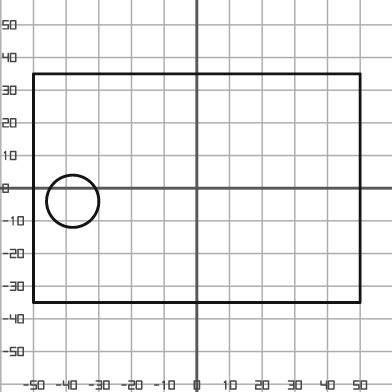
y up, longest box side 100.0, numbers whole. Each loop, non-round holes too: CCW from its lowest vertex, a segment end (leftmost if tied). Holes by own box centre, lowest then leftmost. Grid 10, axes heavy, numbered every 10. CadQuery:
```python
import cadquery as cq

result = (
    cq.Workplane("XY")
    .moveTo(-50.0, -35.0)
    .lineTo(50.0, -35.0)
    .lineTo(50.0, 35.0)
    .lineTo(-50.0, 35.0)
    .close()
    .moveTo(-38.0, -4.0)
    .circle(8.0)
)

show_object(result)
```